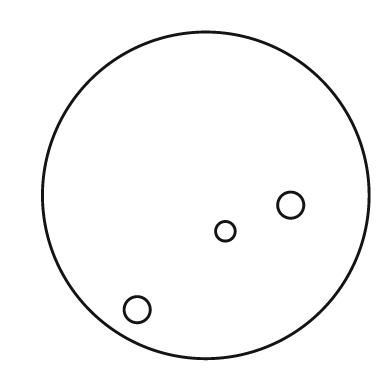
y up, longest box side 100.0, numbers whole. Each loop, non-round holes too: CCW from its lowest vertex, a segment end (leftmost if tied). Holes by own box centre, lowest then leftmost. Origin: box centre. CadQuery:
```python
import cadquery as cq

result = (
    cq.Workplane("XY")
    .moveTo(0.0, 0.0)
    .circle(50.0)
    .moveTo(-21.0, -35.0)
    .circle(4.0)
    .moveTo(6.0, -11.0)
    .circle(3.0)
    .moveTo(26.0, -3.0)
    .circle(4.0)
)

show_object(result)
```